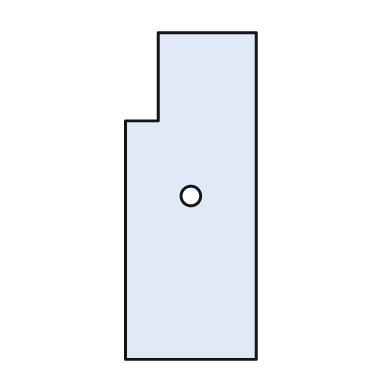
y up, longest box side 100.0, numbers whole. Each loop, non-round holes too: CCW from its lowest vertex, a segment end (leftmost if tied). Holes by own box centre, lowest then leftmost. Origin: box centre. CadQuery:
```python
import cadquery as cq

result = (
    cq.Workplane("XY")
    .moveTo(-20.0, -50.0)
    .lineTo(20.0, -50.0)
    .lineTo(20.0, 50.0)
    .lineTo(-10.0, 50.0)
    .lineTo(-10.0, 23.0)
    .lineTo(-20.0, 23.0)
    .close()
    .moveTo(0.0, 0.0)
    .circle(3.0)
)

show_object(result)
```